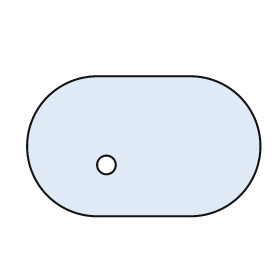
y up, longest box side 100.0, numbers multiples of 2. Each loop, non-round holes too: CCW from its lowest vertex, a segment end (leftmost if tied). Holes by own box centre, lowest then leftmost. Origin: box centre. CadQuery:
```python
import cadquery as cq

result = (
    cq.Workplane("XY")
    .moveTo(-20.0, -30.0)
    .lineTo(20.0, -30.0)
    .threePointArc((50.0, 0.0), (20.0, 30.0))
    .lineTo(-20.0, 30.0)
    .threePointArc((-50.0, 0.0), (-20.0, -30.0))
    .close()
    .moveTo(-16.0, -8.0)
    .circle(4.0)
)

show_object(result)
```